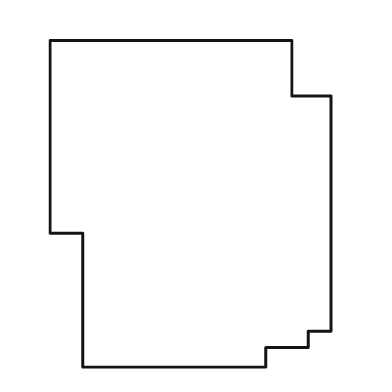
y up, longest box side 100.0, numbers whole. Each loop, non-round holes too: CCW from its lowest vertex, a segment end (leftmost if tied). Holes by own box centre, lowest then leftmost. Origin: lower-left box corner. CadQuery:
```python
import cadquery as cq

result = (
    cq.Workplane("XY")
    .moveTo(10.0, 0.0)
    .lineTo(66.0, 0.0)
    .lineTo(66.0, 6.0)
    .lineTo(79.0, 6.0)
    .lineTo(79.0, 11.0)
    .lineTo(86.0, 11.0)
    .lineTo(86.0, 83.0)
    .lineTo(74.0, 83.0)
    .lineTo(74.0, 100.0)
    .lineTo(0.0, 100.0)
    .lineTo(0.0, 41.0)
    .lineTo(10.0, 41.0)
    .close()
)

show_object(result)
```